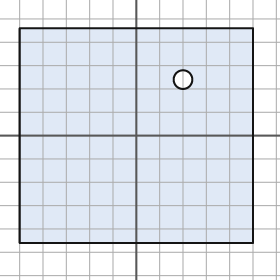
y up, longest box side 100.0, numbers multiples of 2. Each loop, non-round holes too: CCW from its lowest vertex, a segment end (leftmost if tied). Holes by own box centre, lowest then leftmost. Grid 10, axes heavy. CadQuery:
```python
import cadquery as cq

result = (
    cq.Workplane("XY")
    .moveTo(-50.0, -46.0)
    .lineTo(50.0, -46.0)
    .lineTo(50.0, 46.0)
    .lineTo(-50.0, 46.0)
    .close()
    .moveTo(20.0, 24.0)
    .circle(4.0)
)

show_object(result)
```